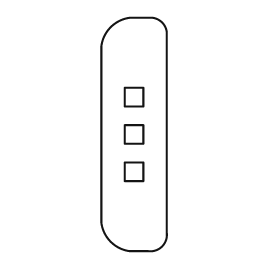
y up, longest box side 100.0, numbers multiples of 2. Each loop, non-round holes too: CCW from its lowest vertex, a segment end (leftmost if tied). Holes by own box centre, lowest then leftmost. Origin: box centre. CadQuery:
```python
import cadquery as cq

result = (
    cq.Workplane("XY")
    .moveTo(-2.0, -50.0)
    .lineTo(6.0, -50.0)
    .threePointArc((12.0, -48.0), (14.0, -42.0))
    .lineTo(14.0, 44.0)
    .threePointArc((12.0, 48.0), (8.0, 50.0))
    .lineTo(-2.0, 50.0)
    .threePointArc((-10.0, 46.0), (-14.0, 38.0))
    .lineTo(-14.0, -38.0)
    .threePointArc((-10.0, -46.0), (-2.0, -50.0))
    .close()
    .moveTo(-4.0, -20.0)
    .lineTo(4.0, -20.0)
    .lineTo(4.0, -12.0)
    .lineTo(-4.0, -12.0)
    .close()
    .moveTo(-4.0, -4.0)
    .lineTo(4.0, -4.0)
    .lineTo(4.0, 4.0)
    .lineTo(-4.0, 4.0)
    .close()
    .moveTo(-4.0, 12.0)
    .lineTo(4.0, 12.0)
    .lineTo(4.0, 20.0)
    .lineTo(-4.0, 20.0)
    .close()
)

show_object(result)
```